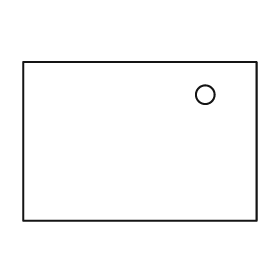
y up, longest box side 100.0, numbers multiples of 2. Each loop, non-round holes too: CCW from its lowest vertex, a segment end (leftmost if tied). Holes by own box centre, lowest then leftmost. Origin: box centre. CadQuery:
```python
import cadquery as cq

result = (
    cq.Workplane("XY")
    .moveTo(-50.0, -34.0)
    .lineTo(50.0, -34.0)
    .lineTo(50.0, 34.0)
    .lineTo(-50.0, 34.0)
    .close()
    .moveTo(28.0, 20.0)
    .circle(4.0)
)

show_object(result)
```